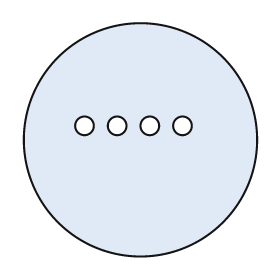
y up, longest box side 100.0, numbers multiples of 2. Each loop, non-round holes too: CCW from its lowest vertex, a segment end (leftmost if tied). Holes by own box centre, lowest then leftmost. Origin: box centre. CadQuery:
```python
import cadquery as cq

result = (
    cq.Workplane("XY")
    .moveTo(0.0, 0.0)
    .circle(50.0)
    .moveTo(-24.0, 6.0)
    .circle(4.0)
    .moveTo(-10.0, 6.0)
    .circle(4.0)
    .moveTo(4.0, 6.0)
    .circle(4.0)
    .moveTo(18.0, 6.0)
    .circle(4.0)
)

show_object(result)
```